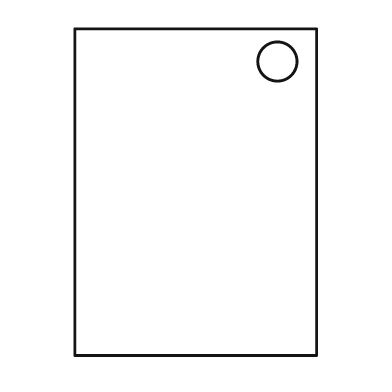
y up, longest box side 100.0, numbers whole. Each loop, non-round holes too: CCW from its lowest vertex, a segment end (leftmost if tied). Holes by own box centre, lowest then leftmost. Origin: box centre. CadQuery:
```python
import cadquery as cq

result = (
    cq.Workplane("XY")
    .moveTo(-37.0, -50.0)
    .lineTo(37.0, -50.0)
    .lineTo(37.0, 50.0)
    .lineTo(-37.0, 50.0)
    .close()
    .moveTo(25.0, 40.0)
    .circle(6.0)
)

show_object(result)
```